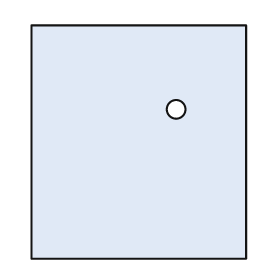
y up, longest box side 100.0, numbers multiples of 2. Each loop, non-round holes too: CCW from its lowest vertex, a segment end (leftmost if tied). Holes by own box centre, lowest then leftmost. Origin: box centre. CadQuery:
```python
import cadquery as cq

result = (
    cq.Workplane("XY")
    .moveTo(-46.0, -50.0)
    .lineTo(46.0, -50.0)
    .lineTo(46.0, 50.0)
    .lineTo(-46.0, 50.0)
    .close()
    .moveTo(16.0, 14.0)
    .circle(4.0)
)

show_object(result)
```